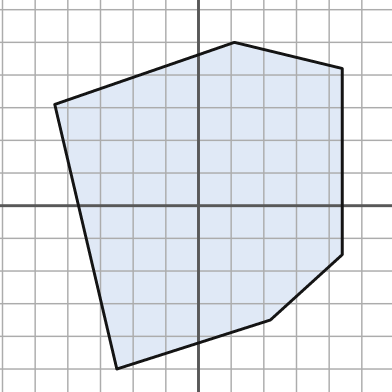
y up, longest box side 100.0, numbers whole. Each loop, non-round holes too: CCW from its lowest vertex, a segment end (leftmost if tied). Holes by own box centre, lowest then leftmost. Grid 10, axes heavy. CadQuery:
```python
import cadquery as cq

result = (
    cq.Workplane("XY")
    .moveTo(-25.0, -50.0)
    .lineTo(22.0, -35.0)
    .lineTo(44.0, -15.0)
    .lineTo(44.0, 42.0)
    .lineTo(11.0, 50.0)
    .lineTo(-44.0, 31.0)
    .close()
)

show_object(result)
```